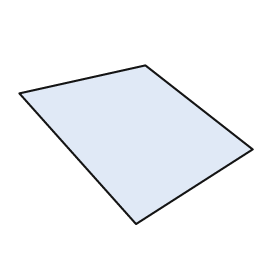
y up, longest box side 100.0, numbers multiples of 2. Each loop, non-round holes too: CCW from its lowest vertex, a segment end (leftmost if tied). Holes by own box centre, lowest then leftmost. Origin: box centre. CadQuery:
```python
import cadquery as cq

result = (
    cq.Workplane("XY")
    .moveTo(0.0, -34.0)
    .lineTo(50.0, -2.0)
    .lineTo(4.0, 34.0)
    .lineTo(-50.0, 22.0)
    .close()
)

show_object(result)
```